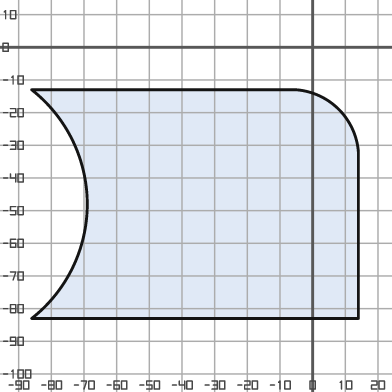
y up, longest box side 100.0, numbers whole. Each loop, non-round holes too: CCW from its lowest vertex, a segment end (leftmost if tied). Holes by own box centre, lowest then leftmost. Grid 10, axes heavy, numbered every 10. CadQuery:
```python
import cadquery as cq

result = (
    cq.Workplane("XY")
    .moveTo(-86.0, -83.0)
    .lineTo(14.0, -83.0)
    .lineTo(14.0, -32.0)
    .threePointArc((8.0, -19.0), (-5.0, -13.0))
    .lineTo(-86.0, -13.0)
    .threePointArc((-69.0, -48.0), (-86.0, -83.0))
    .close()
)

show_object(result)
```